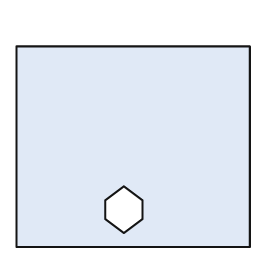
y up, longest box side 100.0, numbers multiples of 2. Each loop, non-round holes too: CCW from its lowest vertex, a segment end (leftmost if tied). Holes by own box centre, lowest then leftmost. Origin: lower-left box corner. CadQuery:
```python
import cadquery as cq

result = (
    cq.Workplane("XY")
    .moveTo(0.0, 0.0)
    .lineTo(100.0, 0.0)
    .lineTo(100.0, 86.0)
    .lineTo(0.0, 86.0)
    .close()
    .moveTo(46.0, 6.0)
    .lineTo(54.0, 12.0)
    .lineTo(54.0, 20.0)
    .lineTo(46.0, 26.0)
    .lineTo(38.0, 20.0)
    .lineTo(38.0, 12.0)
    .close()
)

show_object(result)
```